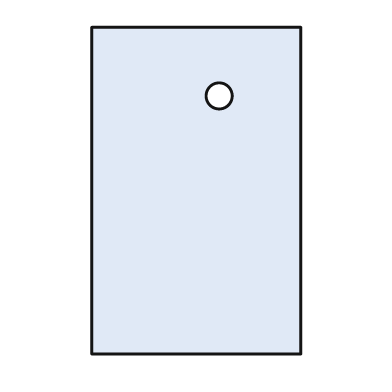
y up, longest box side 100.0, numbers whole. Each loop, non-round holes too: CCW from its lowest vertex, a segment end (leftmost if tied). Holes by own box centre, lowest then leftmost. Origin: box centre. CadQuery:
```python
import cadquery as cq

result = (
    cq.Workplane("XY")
    .moveTo(-32.0, -50.0)
    .lineTo(32.0, -50.0)
    .lineTo(32.0, 50.0)
    .lineTo(-32.0, 50.0)
    .close()
    .moveTo(7.0, 29.0)
    .circle(4.0)
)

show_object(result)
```